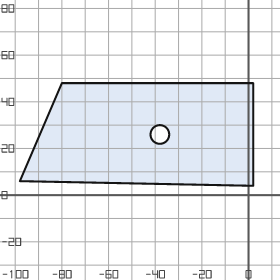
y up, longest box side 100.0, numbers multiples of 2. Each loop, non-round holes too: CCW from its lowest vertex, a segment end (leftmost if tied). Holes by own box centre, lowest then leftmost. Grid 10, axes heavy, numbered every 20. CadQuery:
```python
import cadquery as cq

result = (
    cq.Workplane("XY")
    .moveTo(2.0, 4.0)
    .lineTo(2.0, 48.0)
    .lineTo(-80.0, 48.0)
    .lineTo(-98.0, 6.0)
    .close()
    .moveTo(-38.0, 26.0)
    .circle(4.0)
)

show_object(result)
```